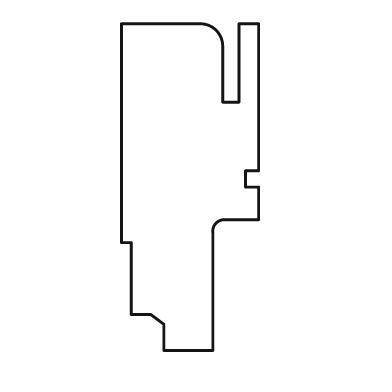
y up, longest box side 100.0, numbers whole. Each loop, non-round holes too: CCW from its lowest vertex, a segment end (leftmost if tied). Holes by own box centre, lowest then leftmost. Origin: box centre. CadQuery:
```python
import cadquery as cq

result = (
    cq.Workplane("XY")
    .moveTo(-8.0, -50.0)
    .lineTo(7.0, -50.0)
    .lineTo(7.0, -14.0)
    .threePointArc((8.0, -11.0), (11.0, -10.0))
    .lineTo(21.0, -10.0)
    .lineTo(21.0, 0.0)
    .lineTo(17.0, 0.0)
    .lineTo(17.0, 5.0)
    .lineTo(21.0, 5.0)
    .lineTo(21.0, 50.0)
    .lineTo(15.0, 50.0)
    .lineTo(15.0, 26.0)
    .lineTo(10.0, 26.0)
    .lineTo(10.0, 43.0)
    .threePointArc((8.0, 48.0), (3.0, 50.0))
    .lineTo(-21.0, 50.0)
    .lineTo(-21.0, -17.0)
    .lineTo(-18.0, -17.0)
    .lineTo(-18.0, -39.0)
    .lineTo(-12.0, -39.0)
    .lineTo(-8.0, -42.0)
    .close()
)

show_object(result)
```